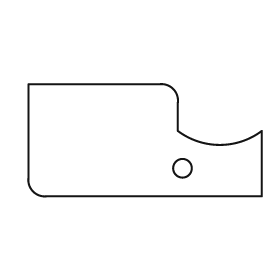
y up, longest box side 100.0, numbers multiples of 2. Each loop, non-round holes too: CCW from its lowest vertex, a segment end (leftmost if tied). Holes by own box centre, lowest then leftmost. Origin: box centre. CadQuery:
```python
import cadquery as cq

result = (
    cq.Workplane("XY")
    .moveTo(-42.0, -24.0)
    .lineTo(50.0, -24.0)
    .lineTo(50.0, 4.0)
    .threePointArc((32.0, -2.0), (14.0, 4.0))
    .lineTo(14.0, 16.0)
    .threePointArc((12.0, 22.0), (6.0, 24.0))
    .lineTo(-50.0, 24.0)
    .lineTo(-50.0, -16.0)
    .threePointArc((-48.0, -22.0), (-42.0, -24.0))
    .close()
    .moveTo(16.0, -12.0)
    .circle(4.0)
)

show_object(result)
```